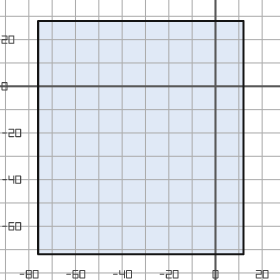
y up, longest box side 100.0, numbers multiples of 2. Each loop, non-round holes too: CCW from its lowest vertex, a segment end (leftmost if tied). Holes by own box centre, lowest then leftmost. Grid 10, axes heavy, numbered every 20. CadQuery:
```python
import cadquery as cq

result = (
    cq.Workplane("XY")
    .moveTo(-76.0, -72.0)
    .lineTo(12.0, -72.0)
    .lineTo(12.0, 28.0)
    .lineTo(-76.0, 28.0)
    .close()
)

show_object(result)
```